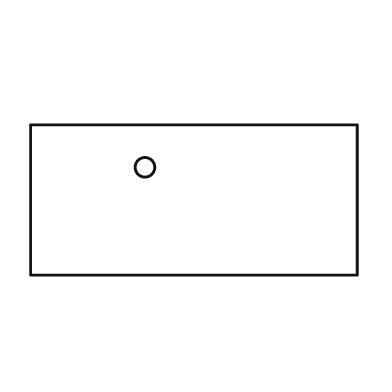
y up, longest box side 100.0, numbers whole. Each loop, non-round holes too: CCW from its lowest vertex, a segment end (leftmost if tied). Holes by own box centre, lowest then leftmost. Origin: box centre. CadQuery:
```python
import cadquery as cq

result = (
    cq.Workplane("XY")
    .moveTo(-50.0, -23.0)
    .lineTo(50.0, -23.0)
    .lineTo(50.0, 23.0)
    .lineTo(-50.0, 23.0)
    .close()
    .moveTo(-15.0, 10.0)
    .circle(3.0)
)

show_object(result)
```